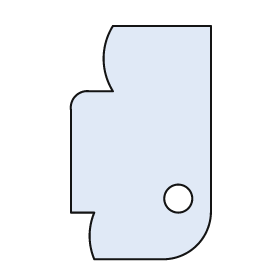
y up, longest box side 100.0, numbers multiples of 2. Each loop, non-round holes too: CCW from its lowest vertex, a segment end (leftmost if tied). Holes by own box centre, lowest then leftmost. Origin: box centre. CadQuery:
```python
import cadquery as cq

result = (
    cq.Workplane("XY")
    .moveTo(-20.0, -50.0)
    .lineTo(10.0, -50.0)
    .threePointArc((24.0, -44.0), (30.0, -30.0))
    .lineTo(30.0, 50.0)
    .lineTo(-12.0, 50.0)
    .threePointArc((-16.0, 36.0), (-12.0, 22.0))
    .lineTo(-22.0, 22.0)
    .threePointArc((-28.0, 20.0), (-30.0, 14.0))
    .lineTo(-30.0, -30.0)
    .lineTo(-20.0, -30.0)
    .threePointArc((-22.0, -40.0), (-20.0, -50.0))
    .close()
    .moveTo(16.0, -24.0)
    .circle(6.0)
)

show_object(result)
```